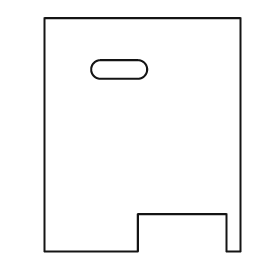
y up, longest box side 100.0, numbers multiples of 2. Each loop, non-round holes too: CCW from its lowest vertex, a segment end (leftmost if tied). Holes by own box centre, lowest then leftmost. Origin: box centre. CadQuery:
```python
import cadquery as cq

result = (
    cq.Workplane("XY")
    .moveTo(-42.0, -50.0)
    .lineTo(-2.0, -50.0)
    .lineTo(-2.0, -34.0)
    .lineTo(36.0, -34.0)
    .lineTo(36.0, -50.0)
    .lineTo(42.0, -50.0)
    .lineTo(42.0, 50.0)
    .lineTo(-42.0, 50.0)
    .close()
    .moveTo(-18.0, 24.0)
    .lineTo(-2.0, 24.0)
    .threePointArc((2.0, 28.0), (-2.0, 32.0))
    .lineTo(-18.0, 32.0)
    .threePointArc((-22.0, 28.0), (-18.0, 24.0))
    .close()
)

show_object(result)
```